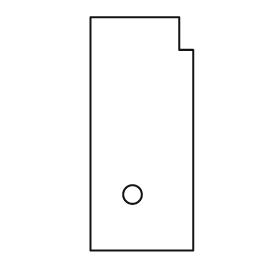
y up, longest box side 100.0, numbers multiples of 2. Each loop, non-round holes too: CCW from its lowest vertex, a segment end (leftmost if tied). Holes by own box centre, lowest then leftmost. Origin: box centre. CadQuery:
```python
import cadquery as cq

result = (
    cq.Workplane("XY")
    .moveTo(-22.0, -50.0)
    .lineTo(22.0, -50.0)
    .lineTo(22.0, 36.0)
    .lineTo(16.0, 36.0)
    .lineTo(16.0, 50.0)
    .lineTo(-22.0, 50.0)
    .close()
    .moveTo(-4.0, -26.0)
    .circle(4.0)
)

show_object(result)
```